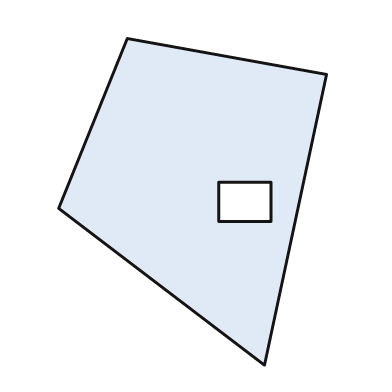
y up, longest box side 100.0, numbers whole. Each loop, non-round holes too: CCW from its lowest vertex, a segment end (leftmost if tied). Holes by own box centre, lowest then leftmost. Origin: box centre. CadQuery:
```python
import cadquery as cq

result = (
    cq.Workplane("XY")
    .moveTo(22.0, -50.0)
    .lineTo(41.0, 39.0)
    .lineTo(-20.0, 50.0)
    .lineTo(-41.0, -2.0)
    .close()
    .moveTo(8.0, -6.0)
    .lineTo(24.0, -6.0)
    .lineTo(24.0, 6.0)
    .lineTo(8.0, 6.0)
    .close()
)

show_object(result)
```